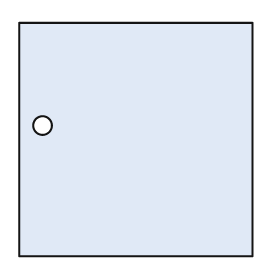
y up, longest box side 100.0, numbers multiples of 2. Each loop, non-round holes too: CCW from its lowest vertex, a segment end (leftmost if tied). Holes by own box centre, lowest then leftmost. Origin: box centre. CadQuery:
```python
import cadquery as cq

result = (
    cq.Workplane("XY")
    .moveTo(-50.0, -50.0)
    .lineTo(50.0, -50.0)
    .lineTo(50.0, 50.0)
    .lineTo(-50.0, 50.0)
    .close()
    .moveTo(-40.0, 6.0)
    .circle(4.0)
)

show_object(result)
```